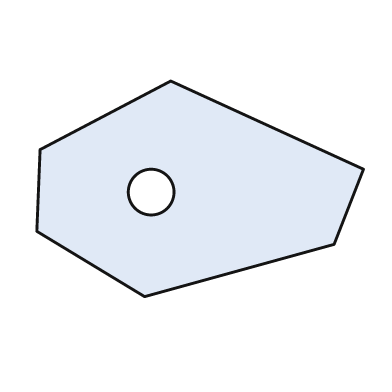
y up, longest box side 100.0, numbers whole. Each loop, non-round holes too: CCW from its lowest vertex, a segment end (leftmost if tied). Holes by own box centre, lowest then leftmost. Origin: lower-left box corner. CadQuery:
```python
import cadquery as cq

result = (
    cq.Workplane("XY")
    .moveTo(33.0, 0.0)
    .lineTo(91.0, 16.0)
    .lineTo(100.0, 39.0)
    .lineTo(41.0, 66.0)
    .lineTo(1.0, 45.0)
    .lineTo(0.0, 20.0)
    .close()
    .moveTo(35.0, 32.0)
    .circle(7.0)
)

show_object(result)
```